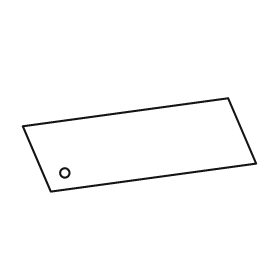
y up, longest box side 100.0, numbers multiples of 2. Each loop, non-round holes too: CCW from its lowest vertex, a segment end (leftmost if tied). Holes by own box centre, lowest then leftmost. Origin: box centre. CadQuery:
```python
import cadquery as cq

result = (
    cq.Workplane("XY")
    .moveTo(-38.0, -20.0)
    .lineTo(50.0, -8.0)
    .lineTo(38.0, 20.0)
    .lineTo(-50.0, 8.0)
    .close()
    .moveTo(-32.0, -12.0)
    .circle(2.0)
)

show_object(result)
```